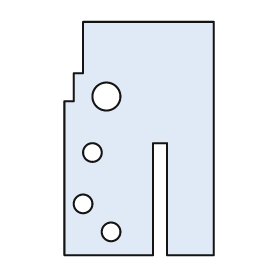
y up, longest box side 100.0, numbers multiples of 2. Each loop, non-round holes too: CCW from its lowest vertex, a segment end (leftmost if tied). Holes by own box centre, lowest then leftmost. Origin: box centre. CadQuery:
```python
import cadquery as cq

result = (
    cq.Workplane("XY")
    .moveTo(-32.0, -50.0)
    .lineTo(6.0, -50.0)
    .lineTo(6.0, -2.0)
    .lineTo(12.0, -2.0)
    .lineTo(12.0, -50.0)
    .lineTo(32.0, -50.0)
    .lineTo(32.0, 50.0)
    .lineTo(-24.0, 50.0)
    .lineTo(-24.0, 28.0)
    .lineTo(-28.0, 28.0)
    .lineTo(-28.0, 16.0)
    .lineTo(-32.0, 16.0)
    .close()
    .moveTo(-12.0, -40.0)
    .circle(4.0)
    .moveTo(-24.0, -28.0)
    .circle(4.0)
    .moveTo(-20.0, -6.0)
    .circle(4.0)
    .moveTo(-14.0, 18.0)
    .circle(6.0)
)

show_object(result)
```